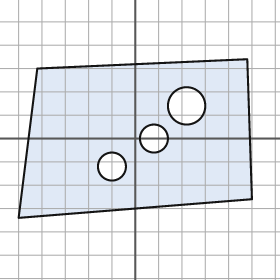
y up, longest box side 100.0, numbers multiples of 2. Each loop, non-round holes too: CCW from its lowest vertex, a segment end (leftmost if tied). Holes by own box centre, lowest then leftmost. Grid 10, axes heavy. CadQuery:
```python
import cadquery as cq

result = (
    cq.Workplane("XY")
    .moveTo(-50.0, -34.0)
    .lineTo(50.0, -26.0)
    .lineTo(48.0, 34.0)
    .lineTo(-42.0, 30.0)
    .close()
    .moveTo(-10.0, -12.0)
    .circle(6.0)
    .moveTo(8.0, 0.0)
    .circle(6.0)
    .moveTo(22.0, 14.0)
    .circle(8.0)
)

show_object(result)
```